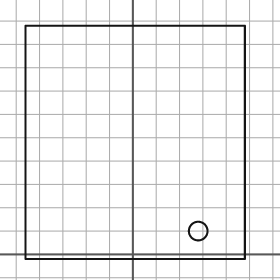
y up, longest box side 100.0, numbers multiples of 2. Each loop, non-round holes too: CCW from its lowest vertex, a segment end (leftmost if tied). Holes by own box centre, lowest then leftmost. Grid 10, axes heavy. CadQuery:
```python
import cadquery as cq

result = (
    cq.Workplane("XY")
    .moveTo(-46.0, -2.0)
    .lineTo(48.0, -2.0)
    .lineTo(48.0, 98.0)
    .lineTo(-46.0, 98.0)
    .close()
    .moveTo(28.0, 10.0)
    .circle(4.0)
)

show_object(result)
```